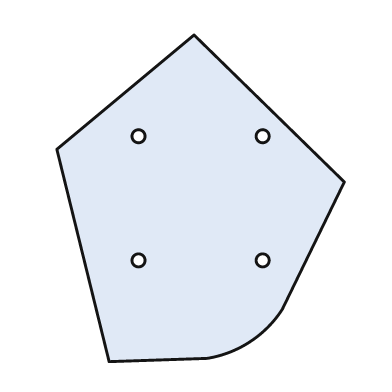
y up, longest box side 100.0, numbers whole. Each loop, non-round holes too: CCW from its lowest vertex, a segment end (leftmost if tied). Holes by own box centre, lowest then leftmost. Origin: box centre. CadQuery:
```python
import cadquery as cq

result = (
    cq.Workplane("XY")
    .moveTo(-28.0, -50.0)
    .lineTo(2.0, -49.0)
    .threePointArc((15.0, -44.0), (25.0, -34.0))
    .lineTo(44.0, 5.0)
    .lineTo(-2.0, 50.0)
    .lineTo(-44.0, 15.0)
    .close()
    .moveTo(-19.0, -19.0)
    .circle(2.0)
    .moveTo(19.0, -19.0)
    .circle(2.0)
    .moveTo(-19.0, 19.0)
    .circle(2.0)
    .moveTo(19.0, 19.0)
    .circle(2.0)
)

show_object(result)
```